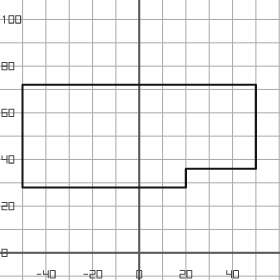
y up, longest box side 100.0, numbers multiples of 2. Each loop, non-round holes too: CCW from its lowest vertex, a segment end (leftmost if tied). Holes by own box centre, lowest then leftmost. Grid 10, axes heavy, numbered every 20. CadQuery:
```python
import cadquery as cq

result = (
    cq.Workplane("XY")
    .moveTo(-50.0, 28.0)
    .lineTo(20.0, 28.0)
    .lineTo(20.0, 36.0)
    .lineTo(50.0, 36.0)
    .lineTo(50.0, 72.0)
    .lineTo(-50.0, 72.0)
    .close()
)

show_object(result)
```